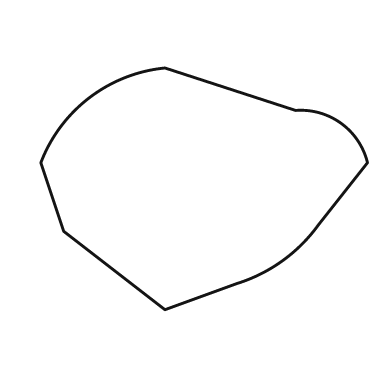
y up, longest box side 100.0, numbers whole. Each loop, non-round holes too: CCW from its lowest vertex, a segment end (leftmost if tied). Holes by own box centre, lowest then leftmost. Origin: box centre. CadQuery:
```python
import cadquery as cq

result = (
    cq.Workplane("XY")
    .moveTo(-12.0, -37.0)
    .lineTo(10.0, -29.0)
    .threePointArc((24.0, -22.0), (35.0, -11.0))
    .lineTo(50.0, 8.0)
    .threePointArc((42.0, 20.0), (28.0, 24.0))
    .lineTo(-12.0, 37.0)
    .threePointArc((-35.0, 28.0), (-50.0, 8.0))
    .lineTo(-43.0, -13.0)
    .close()
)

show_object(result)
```